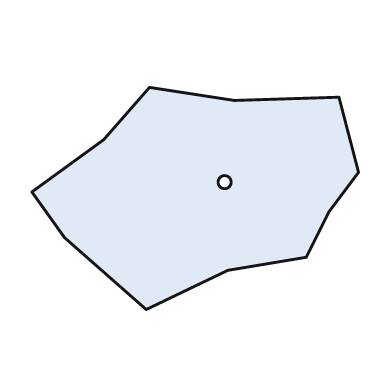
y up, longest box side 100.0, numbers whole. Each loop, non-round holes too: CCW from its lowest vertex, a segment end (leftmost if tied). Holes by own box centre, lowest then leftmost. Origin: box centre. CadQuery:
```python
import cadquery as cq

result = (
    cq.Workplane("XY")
    .moveTo(-15.0, -34.0)
    .lineTo(10.0, -22.0)
    .lineTo(34.0, -18.0)
    .lineTo(41.0, -4.0)
    .lineTo(50.0, 8.0)
    .lineTo(44.0, 31.0)
    .lineTo(12.0, 30.0)
    .lineTo(-14.0, 34.0)
    .lineTo(-28.0, 18.0)
    .lineTo(-50.0, 2.0)
    .lineTo(-40.0, -12.0)
    .close()
    .moveTo(9.0, 5.0)
    .circle(2.0)
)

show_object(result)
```